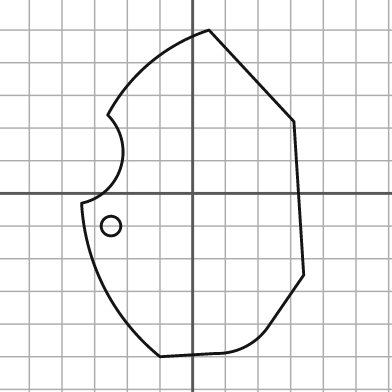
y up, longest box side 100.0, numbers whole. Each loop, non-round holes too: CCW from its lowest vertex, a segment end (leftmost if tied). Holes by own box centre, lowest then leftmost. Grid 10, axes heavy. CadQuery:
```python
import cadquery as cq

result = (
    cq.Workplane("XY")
    .moveTo(-10.0, -50.0)
    .lineTo(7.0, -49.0)
    .threePointArc((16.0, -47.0), (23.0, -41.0))
    .lineTo(34.0, -25.0)
    .lineTo(31.0, 22.0)
    .lineTo(5.0, 50.0)
    .threePointArc((-13.0, 40.0), (-26.0, 24.0))
    .threePointArc((-22.0, 8.0), (-34.0, -3.0))
    .threePointArc((-27.0, -29.0), (-10.0, -50.0))
    .close()
    .moveTo(-25.0, -10.0)
    .circle(3.0)
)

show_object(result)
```